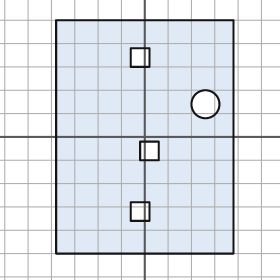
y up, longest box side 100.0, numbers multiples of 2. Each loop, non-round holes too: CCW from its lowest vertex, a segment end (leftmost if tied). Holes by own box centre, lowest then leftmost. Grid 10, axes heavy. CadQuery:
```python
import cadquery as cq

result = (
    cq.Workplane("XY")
    .moveTo(-38.0, -50.0)
    .lineTo(38.0, -50.0)
    .lineTo(38.0, 50.0)
    .lineTo(-38.0, 50.0)
    .close()
    .moveTo(-6.0, -36.0)
    .lineTo(2.0, -36.0)
    .lineTo(2.0, -28.0)
    .lineTo(-6.0, -28.0)
    .close()
    .moveTo(-2.0, -10.0)
    .lineTo(6.0, -10.0)
    .lineTo(6.0, -2.0)
    .lineTo(-2.0, -2.0)
    .close()
    .moveTo(26.0, 14.0)
    .circle(6.0)
    .moveTo(-6.0, 30.0)
    .lineTo(2.0, 30.0)
    .lineTo(2.0, 38.0)
    .lineTo(-6.0, 38.0)
    .close()
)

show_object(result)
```